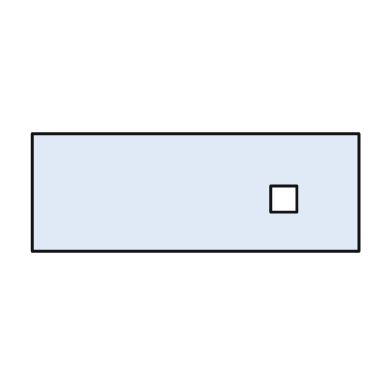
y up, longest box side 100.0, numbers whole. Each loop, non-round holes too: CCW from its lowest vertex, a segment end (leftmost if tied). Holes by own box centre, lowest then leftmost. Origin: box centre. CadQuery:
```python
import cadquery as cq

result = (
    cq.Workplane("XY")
    .moveTo(-50.0, -18.0)
    .lineTo(50.0, -18.0)
    .lineTo(50.0, 18.0)
    .lineTo(-50.0, 18.0)
    .close()
    .moveTo(23.0, -6.0)
    .lineTo(31.0, -6.0)
    .lineTo(31.0, 2.0)
    .lineTo(23.0, 2.0)
    .close()
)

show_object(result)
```